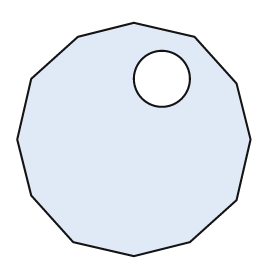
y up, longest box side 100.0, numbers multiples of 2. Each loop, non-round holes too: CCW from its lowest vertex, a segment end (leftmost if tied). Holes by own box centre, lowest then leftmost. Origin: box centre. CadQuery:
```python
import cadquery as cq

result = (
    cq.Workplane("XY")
    .moveTo(0.0, -50.0)
    .lineTo(24.0, -44.0)
    .lineTo(44.0, -26.0)
    .lineTo(50.0, 0.0)
    .lineTo(44.0, 24.0)
    .lineTo(26.0, 44.0)
    .lineTo(0.0, 50.0)
    .lineTo(-24.0, 44.0)
    .lineTo(-44.0, 26.0)
    .lineTo(-50.0, 0.0)
    .lineTo(-44.0, -24.0)
    .lineTo(-26.0, -44.0)
    .close()
    .moveTo(12.0, 26.0)
    .circle(12.0)
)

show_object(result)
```